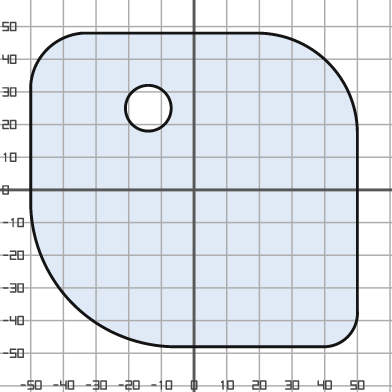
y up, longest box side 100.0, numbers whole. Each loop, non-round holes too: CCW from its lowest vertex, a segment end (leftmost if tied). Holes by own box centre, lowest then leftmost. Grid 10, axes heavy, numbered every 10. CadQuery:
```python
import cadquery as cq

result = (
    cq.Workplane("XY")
    .moveTo(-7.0, -48.0)
    .lineTo(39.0, -48.0)
    .threePointArc((47.0, -45.0), (50.0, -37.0))
    .lineTo(50.0, 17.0)
    .threePointArc((41.0, 39.0), (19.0, 48.0))
    .lineTo(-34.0, 48.0)
    .threePointArc((-45.0, 43.0), (-50.0, 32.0))
    .lineTo(-50.0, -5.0)
    .threePointArc((-37.0, -35.0), (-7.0, -48.0))
    .close()
    .moveTo(-14.0, 25.0)
    .circle(7.0)
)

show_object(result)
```